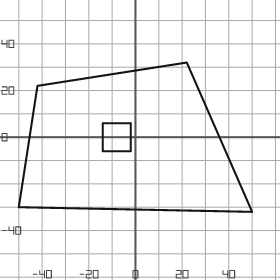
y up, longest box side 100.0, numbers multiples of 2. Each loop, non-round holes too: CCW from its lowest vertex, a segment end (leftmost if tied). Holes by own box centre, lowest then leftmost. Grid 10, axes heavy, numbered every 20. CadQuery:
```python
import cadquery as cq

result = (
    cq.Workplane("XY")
    .moveTo(50.0, -32.0)
    .lineTo(22.0, 32.0)
    .lineTo(-42.0, 22.0)
    .lineTo(-50.0, -30.0)
    .close()
    .moveTo(-14.0, -6.0)
    .lineTo(-2.0, -6.0)
    .lineTo(-2.0, 6.0)
    .lineTo(-14.0, 6.0)
    .close()
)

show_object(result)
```